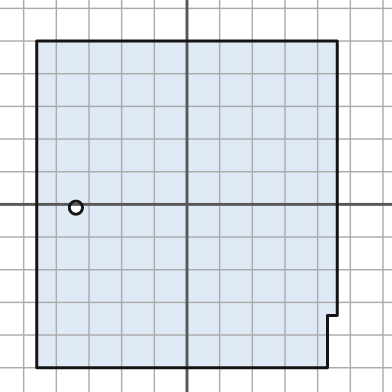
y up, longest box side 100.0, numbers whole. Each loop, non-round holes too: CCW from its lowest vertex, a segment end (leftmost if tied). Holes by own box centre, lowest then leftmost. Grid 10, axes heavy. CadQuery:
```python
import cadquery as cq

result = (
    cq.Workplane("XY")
    .moveTo(-46.0, -50.0)
    .lineTo(43.0, -50.0)
    .lineTo(43.0, -34.0)
    .lineTo(46.0, -34.0)
    .lineTo(46.0, 50.0)
    .lineTo(-46.0, 50.0)
    .close()
    .moveTo(-34.0, -1.0)
    .circle(2.0)
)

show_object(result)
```